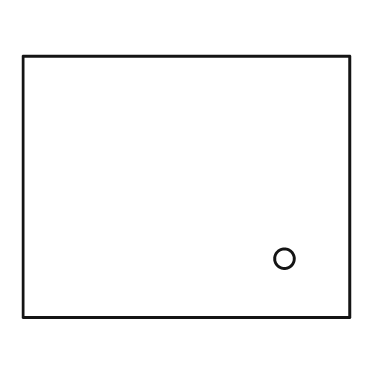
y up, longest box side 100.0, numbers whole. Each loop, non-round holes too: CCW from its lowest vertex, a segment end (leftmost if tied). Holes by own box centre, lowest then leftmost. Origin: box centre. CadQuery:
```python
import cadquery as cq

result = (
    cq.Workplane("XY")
    .moveTo(-50.0, -40.0)
    .lineTo(50.0, -40.0)
    .lineTo(50.0, 40.0)
    .lineTo(-50.0, 40.0)
    .close()
    .moveTo(30.0, -22.0)
    .circle(3.0)
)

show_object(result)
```